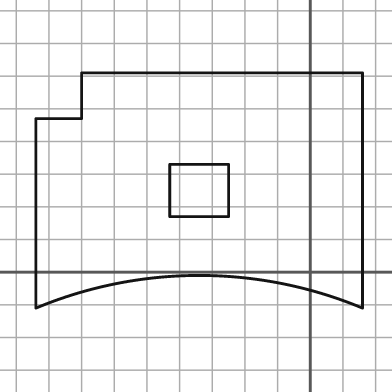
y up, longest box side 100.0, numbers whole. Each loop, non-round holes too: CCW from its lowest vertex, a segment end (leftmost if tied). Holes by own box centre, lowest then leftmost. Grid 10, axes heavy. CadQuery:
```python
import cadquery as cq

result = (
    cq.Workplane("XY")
    .moveTo(-84.0, -11.0)
    .threePointArc((-34.0, -1.0), (16.0, -11.0))
    .lineTo(16.0, 61.0)
    .lineTo(-70.0, 61.0)
    .lineTo(-70.0, 47.0)
    .lineTo(-84.0, 47.0)
    .close()
    .moveTo(-43.0, 17.0)
    .lineTo(-25.0, 17.0)
    .lineTo(-25.0, 33.0)
    .lineTo(-43.0, 33.0)
    .close()
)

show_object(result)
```